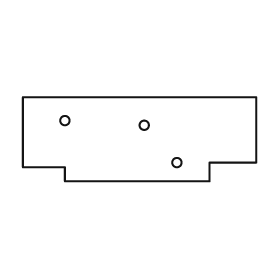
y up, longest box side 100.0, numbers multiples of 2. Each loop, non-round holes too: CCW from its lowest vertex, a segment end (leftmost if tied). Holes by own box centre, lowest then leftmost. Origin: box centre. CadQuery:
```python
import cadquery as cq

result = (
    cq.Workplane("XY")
    .moveTo(-32.0, -18.0)
    .lineTo(30.0, -18.0)
    .lineTo(30.0, -10.0)
    .lineTo(50.0, -10.0)
    .lineTo(50.0, 18.0)
    .lineTo(-50.0, 18.0)
    .lineTo(-50.0, -12.0)
    .lineTo(-32.0, -12.0)
    .close()
    .moveTo(16.0, -10.0)
    .circle(2.0)
    .moveTo(2.0, 6.0)
    .circle(2.0)
    .moveTo(-32.0, 8.0)
    .circle(2.0)
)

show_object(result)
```